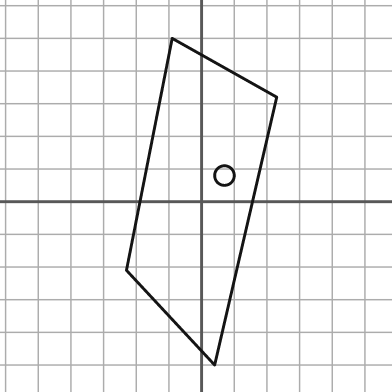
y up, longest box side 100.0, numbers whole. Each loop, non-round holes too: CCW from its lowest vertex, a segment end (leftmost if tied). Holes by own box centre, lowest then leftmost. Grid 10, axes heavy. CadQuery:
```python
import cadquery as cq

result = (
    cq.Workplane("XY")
    .moveTo(4.0, -50.0)
    .lineTo(23.0, 32.0)
    .lineTo(-9.0, 50.0)
    .lineTo(-23.0, -21.0)
    .close()
    .moveTo(7.0, 8.0)
    .circle(3.0)
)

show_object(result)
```